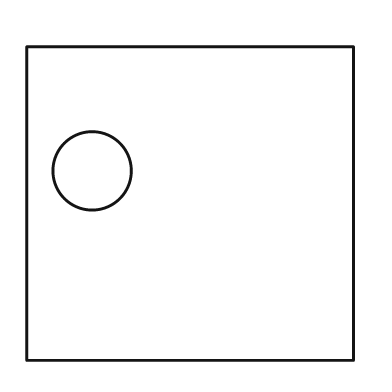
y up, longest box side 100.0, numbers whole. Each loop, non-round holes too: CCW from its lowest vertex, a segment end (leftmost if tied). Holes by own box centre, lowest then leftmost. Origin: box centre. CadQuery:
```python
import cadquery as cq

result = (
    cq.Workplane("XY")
    .moveTo(-50.0, -48.0)
    .lineTo(50.0, -48.0)
    .lineTo(50.0, 48.0)
    .lineTo(-50.0, 48.0)
    .close()
    .moveTo(-30.0, 10.0)
    .circle(12.0)
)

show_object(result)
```